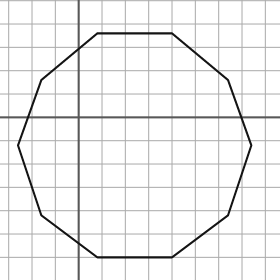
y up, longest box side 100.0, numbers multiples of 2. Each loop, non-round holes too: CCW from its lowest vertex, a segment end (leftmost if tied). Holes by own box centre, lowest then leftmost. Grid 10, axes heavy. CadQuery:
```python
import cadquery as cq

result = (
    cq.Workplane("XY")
    .moveTo(8.0, -60.0)
    .lineTo(40.0, -60.0)
    .lineTo(64.0, -42.0)
    .lineTo(74.0, -12.0)
    .lineTo(64.0, 16.0)
    .lineTo(40.0, 36.0)
    .lineTo(8.0, 36.0)
    .lineTo(-16.0, 16.0)
    .lineTo(-26.0, -12.0)
    .lineTo(-16.0, -42.0)
    .close()
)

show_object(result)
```